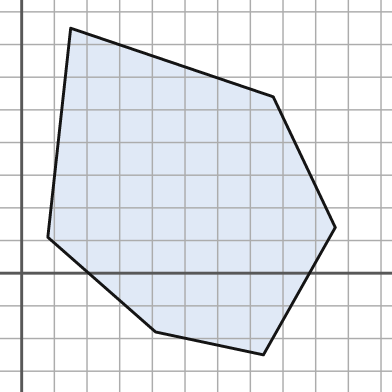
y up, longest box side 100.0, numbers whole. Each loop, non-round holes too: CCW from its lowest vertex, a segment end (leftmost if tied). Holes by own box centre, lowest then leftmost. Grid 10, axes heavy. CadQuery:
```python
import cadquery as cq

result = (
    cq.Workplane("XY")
    .moveTo(74.0, -25.0)
    .lineTo(96.0, 14.0)
    .lineTo(77.0, 54.0)
    .lineTo(15.0, 75.0)
    .lineTo(8.0, 11.0)
    .lineTo(41.0, -18.0)
    .close()
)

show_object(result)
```